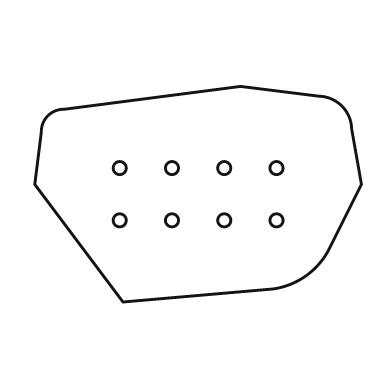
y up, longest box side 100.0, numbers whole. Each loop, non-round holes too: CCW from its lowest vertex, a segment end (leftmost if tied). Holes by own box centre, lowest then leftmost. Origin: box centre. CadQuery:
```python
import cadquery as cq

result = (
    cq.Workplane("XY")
    .moveTo(-23.0, -33.0)
    .lineTo(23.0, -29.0)
    .threePointArc((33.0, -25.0), (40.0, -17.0))
    .lineTo(50.0, 3.0)
    .lineTo(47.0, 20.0)
    .threePointArc((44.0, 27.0), (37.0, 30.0))
    .lineTo(13.0, 33.0)
    .lineTo(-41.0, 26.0)
    .threePointArc((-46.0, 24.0), (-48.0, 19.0))
    .lineTo(-50.0, 3.0)
    .close()
    .moveTo(-24.0, -8.0)
    .circle(2.0)
    .moveTo(-8.0, -8.0)
    .circle(2.0)
    .moveTo(8.0, -8.0)
    .circle(2.0)
    .moveTo(24.0, -8.0)
    .circle(2.0)
    .moveTo(-24.0, 8.0)
    .circle(2.0)
    .moveTo(-8.0, 8.0)
    .circle(2.0)
    .moveTo(8.0, 8.0)
    .circle(2.0)
    .moveTo(24.0, 8.0)
    .circle(2.0)
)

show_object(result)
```